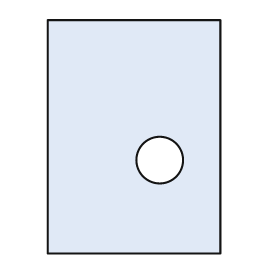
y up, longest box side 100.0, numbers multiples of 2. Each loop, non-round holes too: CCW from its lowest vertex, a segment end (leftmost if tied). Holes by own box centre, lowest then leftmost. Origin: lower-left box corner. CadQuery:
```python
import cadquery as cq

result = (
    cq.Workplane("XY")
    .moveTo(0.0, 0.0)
    .lineTo(74.0, 0.0)
    .lineTo(74.0, 100.0)
    .lineTo(0.0, 100.0)
    .close()
    .moveTo(48.0, 40.0)
    .circle(10.0)
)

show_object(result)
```